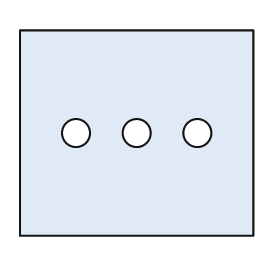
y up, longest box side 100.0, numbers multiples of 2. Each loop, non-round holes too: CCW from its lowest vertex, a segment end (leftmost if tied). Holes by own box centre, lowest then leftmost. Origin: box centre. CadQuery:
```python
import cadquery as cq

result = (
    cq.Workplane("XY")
    .moveTo(-50.0, -44.0)
    .lineTo(50.0, -44.0)
    .lineTo(50.0, 44.0)
    .lineTo(-50.0, 44.0)
    .close()
    .moveTo(-26.0, 0.0)
    .circle(6.0)
    .moveTo(0.0, 0.0)
    .circle(6.0)
    .moveTo(26.0, 0.0)
    .circle(6.0)
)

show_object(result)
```